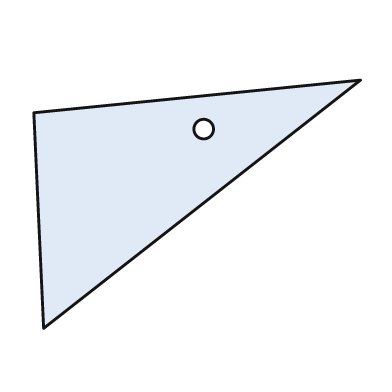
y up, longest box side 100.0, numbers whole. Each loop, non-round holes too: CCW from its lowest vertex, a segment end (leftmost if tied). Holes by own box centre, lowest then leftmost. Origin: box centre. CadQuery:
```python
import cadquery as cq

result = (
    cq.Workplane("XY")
    .moveTo(-47.0, -38.0)
    .lineTo(50.0, 38.0)
    .lineTo(-50.0, 28.0)
    .close()
    .moveTo(2.0, 23.0)
    .circle(3.0)
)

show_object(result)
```